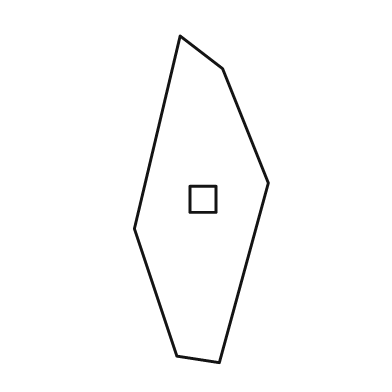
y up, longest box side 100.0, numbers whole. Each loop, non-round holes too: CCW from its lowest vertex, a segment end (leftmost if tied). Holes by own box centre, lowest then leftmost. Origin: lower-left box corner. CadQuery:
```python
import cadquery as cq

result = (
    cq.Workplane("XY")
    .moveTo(26.0, 0.0)
    .lineTo(41.0, 55.0)
    .lineTo(27.0, 90.0)
    .lineTo(14.0, 100.0)
    .lineTo(0.0, 41.0)
    .lineTo(13.0, 2.0)
    .close()
    .moveTo(17.0, 46.0)
    .lineTo(25.0, 46.0)
    .lineTo(25.0, 54.0)
    .lineTo(17.0, 54.0)
    .close()
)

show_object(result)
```